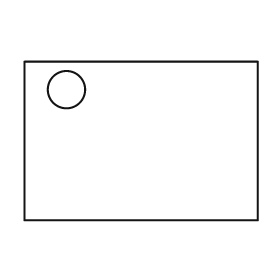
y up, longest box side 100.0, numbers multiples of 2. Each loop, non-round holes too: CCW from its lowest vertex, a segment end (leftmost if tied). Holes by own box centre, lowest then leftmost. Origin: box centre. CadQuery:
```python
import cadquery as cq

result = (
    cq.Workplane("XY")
    .moveTo(-50.0, -34.0)
    .lineTo(50.0, -34.0)
    .lineTo(50.0, 34.0)
    .lineTo(-50.0, 34.0)
    .close()
    .moveTo(-32.0, 22.0)
    .circle(8.0)
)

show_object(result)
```